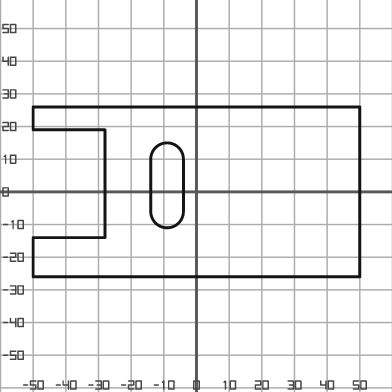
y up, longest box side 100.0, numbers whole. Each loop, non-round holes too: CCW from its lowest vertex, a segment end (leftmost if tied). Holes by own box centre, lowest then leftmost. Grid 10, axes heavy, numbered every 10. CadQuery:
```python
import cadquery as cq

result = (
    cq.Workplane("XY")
    .moveTo(-50.0, -26.0)
    .lineTo(50.0, -26.0)
    .lineTo(50.0, 26.0)
    .lineTo(-50.0, 26.0)
    .lineTo(-50.0, 19.0)
    .lineTo(-28.0, 19.0)
    .lineTo(-28.0, -14.0)
    .lineTo(-50.0, -14.0)
    .close()
    .moveTo(-14.0, -6.0)
    .threePointArc((-9.0, -11.0), (-4.0, -6.0))
    .lineTo(-4.0, 10.0)
    .threePointArc((-9.0, 15.0), (-14.0, 10.0))
    .close()
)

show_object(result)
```